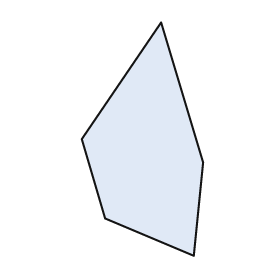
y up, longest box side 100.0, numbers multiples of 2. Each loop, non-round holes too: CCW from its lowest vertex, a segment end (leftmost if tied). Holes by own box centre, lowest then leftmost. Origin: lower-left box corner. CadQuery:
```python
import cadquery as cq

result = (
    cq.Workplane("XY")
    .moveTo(48.0, 0.0)
    .lineTo(52.0, 40.0)
    .lineTo(34.0, 100.0)
    .lineTo(0.0, 50.0)
    .lineTo(10.0, 16.0)
    .close()
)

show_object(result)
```